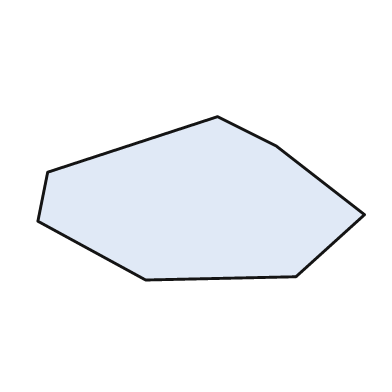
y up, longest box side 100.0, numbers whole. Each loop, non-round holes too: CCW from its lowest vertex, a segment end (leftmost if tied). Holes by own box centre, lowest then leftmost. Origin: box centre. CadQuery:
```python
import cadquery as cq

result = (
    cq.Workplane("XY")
    .moveTo(-17.0, -25.0)
    .lineTo(29.0, -24.0)
    .lineTo(50.0, -5.0)
    .lineTo(23.0, 16.0)
    .lineTo(5.0, 25.0)
    .lineTo(-47.0, 8.0)
    .lineTo(-50.0, -7.0)
    .close()
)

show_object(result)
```